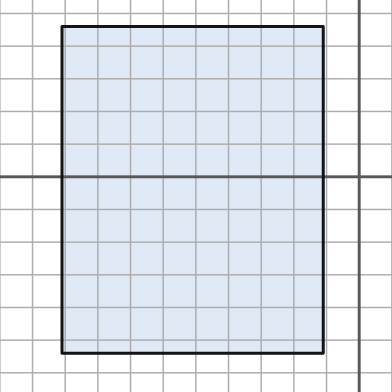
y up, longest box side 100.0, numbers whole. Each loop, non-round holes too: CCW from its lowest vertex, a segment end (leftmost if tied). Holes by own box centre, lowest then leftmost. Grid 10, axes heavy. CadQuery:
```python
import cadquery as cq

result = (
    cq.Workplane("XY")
    .moveTo(-91.0, -54.0)
    .lineTo(-11.0, -54.0)
    .lineTo(-11.0, 46.0)
    .lineTo(-91.0, 46.0)
    .close()
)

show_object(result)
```